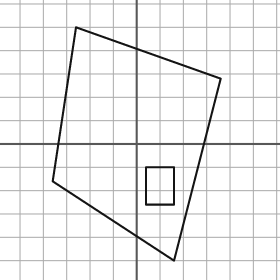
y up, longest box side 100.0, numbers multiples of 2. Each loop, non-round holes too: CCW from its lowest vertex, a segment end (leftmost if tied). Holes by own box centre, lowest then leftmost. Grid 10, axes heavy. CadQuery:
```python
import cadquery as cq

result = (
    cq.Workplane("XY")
    .moveTo(16.0, -50.0)
    .lineTo(36.0, 28.0)
    .lineTo(-26.0, 50.0)
    .lineTo(-36.0, -16.0)
    .close()
    .moveTo(4.0, -26.0)
    .lineTo(16.0, -26.0)
    .lineTo(16.0, -10.0)
    .lineTo(4.0, -10.0)
    .close()
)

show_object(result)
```